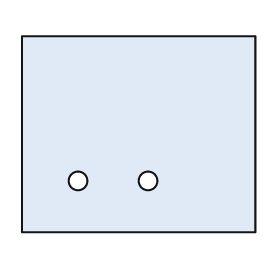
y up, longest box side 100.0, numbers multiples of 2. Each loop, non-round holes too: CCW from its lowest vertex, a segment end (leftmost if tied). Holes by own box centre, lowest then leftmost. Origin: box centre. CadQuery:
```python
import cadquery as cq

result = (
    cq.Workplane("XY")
    .moveTo(-50.0, -42.0)
    .lineTo(50.0, -42.0)
    .lineTo(50.0, 42.0)
    .lineTo(-50.0, 42.0)
    .close()
    .moveTo(-26.0, -20.0)
    .circle(4.0)
    .moveTo(4.0, -20.0)
    .circle(4.0)
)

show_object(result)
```